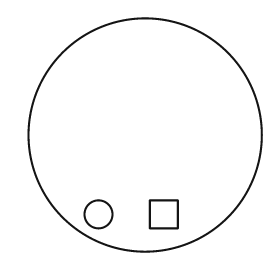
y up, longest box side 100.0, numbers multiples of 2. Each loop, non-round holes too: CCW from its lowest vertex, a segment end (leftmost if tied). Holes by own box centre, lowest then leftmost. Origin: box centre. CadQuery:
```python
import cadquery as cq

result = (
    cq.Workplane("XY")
    .moveTo(0.0, 0.0)
    .circle(50.0)
    .moveTo(-20.0, -34.0)
    .circle(6.0)
    .moveTo(2.0, -40.0)
    .lineTo(14.0, -40.0)
    .lineTo(14.0, -28.0)
    .lineTo(2.0, -28.0)
    .close()
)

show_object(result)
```